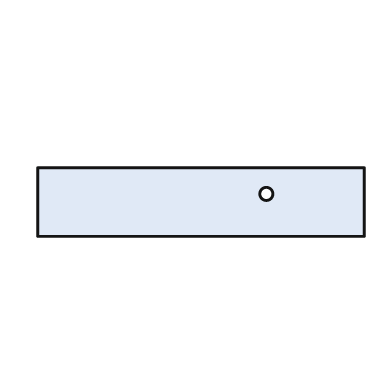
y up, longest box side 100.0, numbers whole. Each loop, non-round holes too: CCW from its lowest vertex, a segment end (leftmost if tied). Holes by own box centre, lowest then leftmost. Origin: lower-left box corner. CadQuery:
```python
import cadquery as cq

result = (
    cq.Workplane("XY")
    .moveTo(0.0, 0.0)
    .lineTo(100.0, 0.0)
    .lineTo(100.0, 21.0)
    .lineTo(0.0, 21.0)
    .close()
    .moveTo(70.0, 13.0)
    .circle(2.0)
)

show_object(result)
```